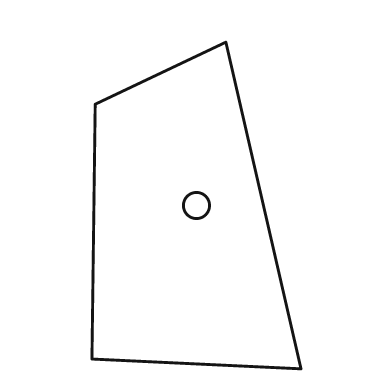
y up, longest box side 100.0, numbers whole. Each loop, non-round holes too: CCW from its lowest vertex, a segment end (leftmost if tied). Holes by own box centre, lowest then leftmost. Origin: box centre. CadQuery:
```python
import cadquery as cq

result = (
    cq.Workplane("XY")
    .moveTo(32.0, -50.0)
    .lineTo(9.0, 50.0)
    .lineTo(-31.0, 31.0)
    .lineTo(-32.0, -47.0)
    .close()
    .moveTo(0.0, 0.0)
    .circle(4.0)
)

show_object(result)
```